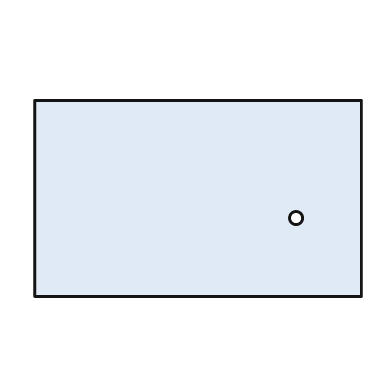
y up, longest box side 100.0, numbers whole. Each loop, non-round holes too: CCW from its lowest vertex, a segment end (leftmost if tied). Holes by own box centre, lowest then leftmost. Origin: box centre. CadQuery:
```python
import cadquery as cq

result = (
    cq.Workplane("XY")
    .moveTo(-50.0, -30.0)
    .lineTo(50.0, -30.0)
    .lineTo(50.0, 30.0)
    .lineTo(-50.0, 30.0)
    .close()
    .moveTo(30.0, -6.0)
    .circle(2.0)
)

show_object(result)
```